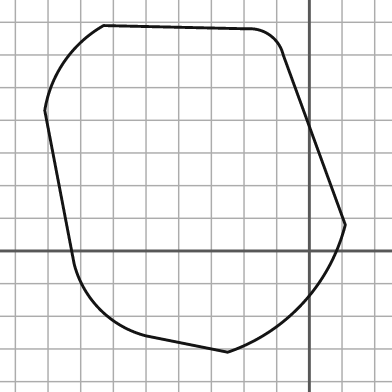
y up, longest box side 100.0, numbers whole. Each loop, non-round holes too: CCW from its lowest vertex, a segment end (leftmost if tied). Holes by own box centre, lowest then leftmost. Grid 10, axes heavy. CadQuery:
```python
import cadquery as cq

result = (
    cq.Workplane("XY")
    .moveTo(-25.0, -31.0)
    .threePointArc((-2.0, -16.0), (11.0, 8.0))
    .lineTo(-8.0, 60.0)
    .threePointArc((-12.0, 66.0), (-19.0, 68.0))
    .lineTo(-63.0, 69.0)
    .threePointArc((-75.0, 58.0), (-81.0, 43.0))
    .lineTo(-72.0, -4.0)
    .threePointArc((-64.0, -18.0), (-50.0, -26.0))
    .close()
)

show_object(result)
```